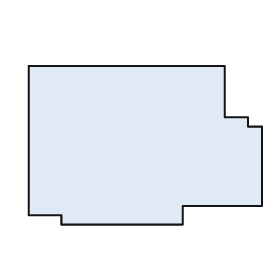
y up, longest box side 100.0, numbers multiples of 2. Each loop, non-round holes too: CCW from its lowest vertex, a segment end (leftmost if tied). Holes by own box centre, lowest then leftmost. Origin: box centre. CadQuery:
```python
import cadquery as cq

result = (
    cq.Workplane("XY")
    .moveTo(-36.0, -34.0)
    .lineTo(16.0, -34.0)
    .lineTo(16.0, -26.0)
    .lineTo(50.0, -26.0)
    .lineTo(50.0, 8.0)
    .lineTo(44.0, 8.0)
    .lineTo(44.0, 12.0)
    .lineTo(34.0, 12.0)
    .lineTo(34.0, 34.0)
    .lineTo(-50.0, 34.0)
    .lineTo(-50.0, -30.0)
    .lineTo(-36.0, -30.0)
    .close()
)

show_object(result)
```